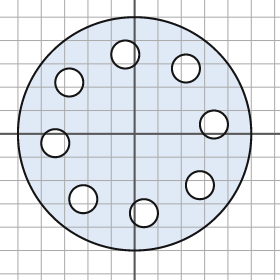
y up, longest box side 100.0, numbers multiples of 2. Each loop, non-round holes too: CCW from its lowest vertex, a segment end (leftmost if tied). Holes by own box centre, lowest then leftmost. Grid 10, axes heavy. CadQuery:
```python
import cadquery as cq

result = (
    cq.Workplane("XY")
    .moveTo(0.0, 0.0)
    .circle(50.0)
    .moveTo(4.0, -34.0)
    .circle(6.0)
    .moveTo(-22.0, -28.0)
    .circle(6.0)
    .moveTo(28.0, -22.0)
    .circle(6.0)
    .moveTo(-34.0, -4.0)
    .circle(6.0)
    .moveTo(34.0, 4.0)
    .circle(6.0)
    .moveTo(-28.0, 22.0)
    .circle(6.0)
    .moveTo(22.0, 28.0)
    .circle(6.0)
    .moveTo(-4.0, 34.0)
    .circle(6.0)
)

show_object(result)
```